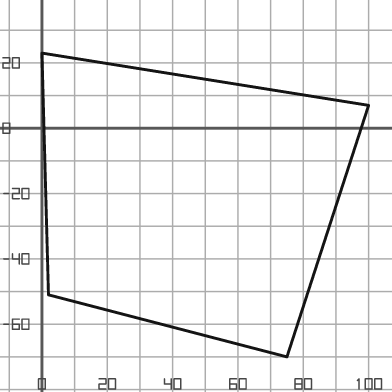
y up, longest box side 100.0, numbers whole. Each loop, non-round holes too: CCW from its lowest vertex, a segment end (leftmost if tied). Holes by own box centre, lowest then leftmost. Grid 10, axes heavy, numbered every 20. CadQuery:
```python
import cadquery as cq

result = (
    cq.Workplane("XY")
    .moveTo(75.0, -70.0)
    .lineTo(100.0, 7.0)
    .lineTo(0.0, 23.0)
    .lineTo(2.0, -51.0)
    .close()
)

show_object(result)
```